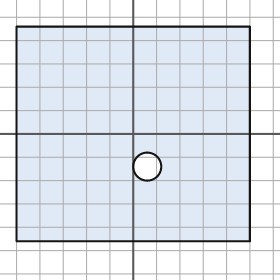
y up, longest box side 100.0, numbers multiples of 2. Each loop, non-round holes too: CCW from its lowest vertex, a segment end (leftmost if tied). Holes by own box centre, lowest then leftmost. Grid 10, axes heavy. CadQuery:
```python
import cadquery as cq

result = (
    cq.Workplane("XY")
    .moveTo(-50.0, -46.0)
    .lineTo(50.0, -46.0)
    .lineTo(50.0, 46.0)
    .lineTo(-50.0, 46.0)
    .close()
    .moveTo(6.0, -14.0)
    .circle(6.0)
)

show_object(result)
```